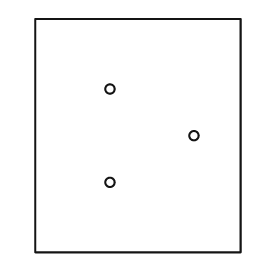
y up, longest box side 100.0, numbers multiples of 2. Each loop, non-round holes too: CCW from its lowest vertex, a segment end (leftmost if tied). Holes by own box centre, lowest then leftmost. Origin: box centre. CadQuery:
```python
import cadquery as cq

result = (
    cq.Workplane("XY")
    .moveTo(-44.0, -50.0)
    .lineTo(44.0, -50.0)
    .lineTo(44.0, 50.0)
    .lineTo(-44.0, 50.0)
    .close()
    .moveTo(-12.0, -20.0)
    .circle(2.0)
    .moveTo(24.0, 0.0)
    .circle(2.0)
    .moveTo(-12.0, 20.0)
    .circle(2.0)
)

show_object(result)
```